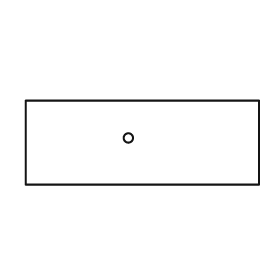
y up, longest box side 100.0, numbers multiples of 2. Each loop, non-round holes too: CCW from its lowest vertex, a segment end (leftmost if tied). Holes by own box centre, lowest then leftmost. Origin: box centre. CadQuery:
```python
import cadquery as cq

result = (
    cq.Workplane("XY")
    .moveTo(-50.0, -18.0)
    .lineTo(50.0, -18.0)
    .lineTo(50.0, 18.0)
    .lineTo(-50.0, 18.0)
    .close()
    .moveTo(-6.0, 2.0)
    .circle(2.0)
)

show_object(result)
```